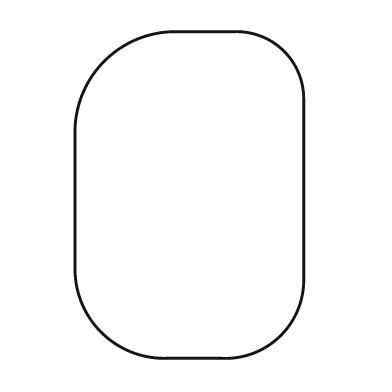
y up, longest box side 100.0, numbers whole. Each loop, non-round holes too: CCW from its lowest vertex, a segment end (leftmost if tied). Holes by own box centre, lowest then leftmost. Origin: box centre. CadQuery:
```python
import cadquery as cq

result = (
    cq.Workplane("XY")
    .moveTo(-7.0, -50.0)
    .lineTo(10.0, -50.0)
    .threePointArc((28.0, -43.0), (35.0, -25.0))
    .lineTo(35.0, 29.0)
    .threePointArc((29.0, 44.0), (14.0, 50.0))
    .lineTo(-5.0, 50.0)
    .threePointArc((-26.0, 41.0), (-35.0, 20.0))
    .lineTo(-35.0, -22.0)
    .threePointArc((-27.0, -42.0), (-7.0, -50.0))
    .close()
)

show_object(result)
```